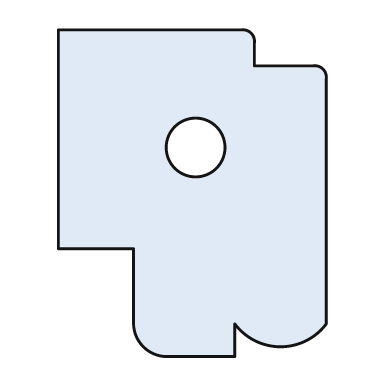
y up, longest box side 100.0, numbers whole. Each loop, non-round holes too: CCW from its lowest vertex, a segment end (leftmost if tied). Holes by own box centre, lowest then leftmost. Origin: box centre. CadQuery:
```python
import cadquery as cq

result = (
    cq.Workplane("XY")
    .moveTo(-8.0, -50.0)
    .lineTo(13.0, -50.0)
    .lineTo(13.0, -40.0)
    .threePointArc((27.0, -47.0), (41.0, -40.0))
    .lineTo(41.0, 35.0)
    .threePointArc((40.0, 38.0), (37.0, 39.0))
    .lineTo(19.0, 39.0)
    .lineTo(19.0, 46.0)
    .threePointArc((18.0, 49.0), (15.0, 50.0))
    .lineTo(-41.0, 50.0)
    .lineTo(-41.0, -17.0)
    .lineTo(-18.0, -17.0)
    .lineTo(-18.0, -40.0)
    .threePointArc((-15.0, -47.0), (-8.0, -50.0))
    .close()
    .moveTo(1.0, 14.0)
    .circle(9.0)
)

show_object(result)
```